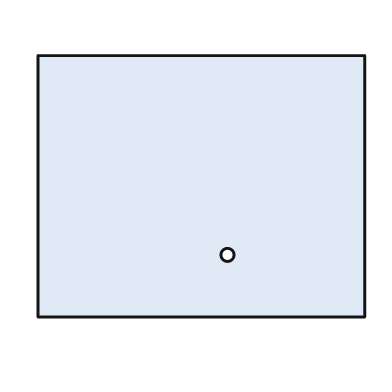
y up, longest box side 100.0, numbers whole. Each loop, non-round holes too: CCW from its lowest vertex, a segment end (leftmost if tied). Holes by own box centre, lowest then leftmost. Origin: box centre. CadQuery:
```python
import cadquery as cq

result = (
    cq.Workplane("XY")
    .moveTo(-50.0, -40.0)
    .lineTo(50.0, -40.0)
    .lineTo(50.0, 40.0)
    .lineTo(-50.0, 40.0)
    .close()
    .moveTo(8.0, -21.0)
    .circle(2.0)
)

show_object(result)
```